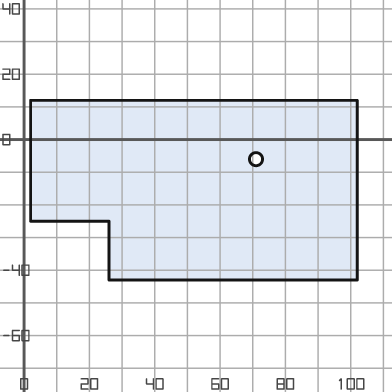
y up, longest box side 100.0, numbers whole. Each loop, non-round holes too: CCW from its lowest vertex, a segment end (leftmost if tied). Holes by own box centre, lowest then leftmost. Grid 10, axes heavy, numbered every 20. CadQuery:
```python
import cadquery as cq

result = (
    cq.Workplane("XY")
    .moveTo(26.0, -43.0)
    .lineTo(102.0, -43.0)
    .lineTo(102.0, 12.0)
    .lineTo(2.0, 12.0)
    .lineTo(2.0, -25.0)
    .lineTo(26.0, -25.0)
    .close()
    .moveTo(71.0, -6.0)
    .circle(2.0)
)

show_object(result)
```